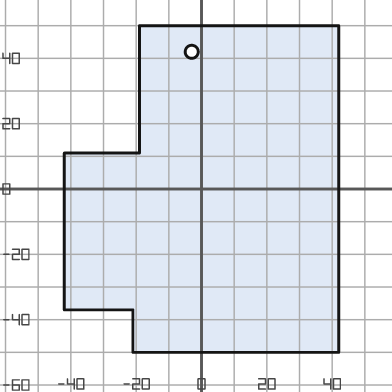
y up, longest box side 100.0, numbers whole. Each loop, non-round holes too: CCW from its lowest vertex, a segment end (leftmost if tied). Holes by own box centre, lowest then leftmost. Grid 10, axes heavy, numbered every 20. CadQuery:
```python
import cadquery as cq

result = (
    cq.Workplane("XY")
    .moveTo(-21.0, -50.0)
    .lineTo(42.0, -50.0)
    .lineTo(42.0, 50.0)
    .lineTo(-19.0, 50.0)
    .lineTo(-19.0, 11.0)
    .lineTo(-42.0, 11.0)
    .lineTo(-42.0, -37.0)
    .lineTo(-21.0, -37.0)
    .close()
    .moveTo(-3.0, 42.0)
    .circle(2.0)
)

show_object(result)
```